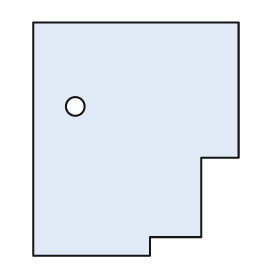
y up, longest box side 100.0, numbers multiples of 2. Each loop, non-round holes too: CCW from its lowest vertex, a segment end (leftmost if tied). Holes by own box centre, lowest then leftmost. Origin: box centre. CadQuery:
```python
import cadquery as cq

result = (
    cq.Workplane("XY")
    .moveTo(-44.0, -50.0)
    .lineTo(6.0, -50.0)
    .lineTo(6.0, -42.0)
    .lineTo(28.0, -42.0)
    .lineTo(28.0, -8.0)
    .lineTo(44.0, -8.0)
    .lineTo(44.0, 50.0)
    .lineTo(-44.0, 50.0)
    .close()
    .moveTo(-26.0, 14.0)
    .circle(4.0)
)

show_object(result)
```